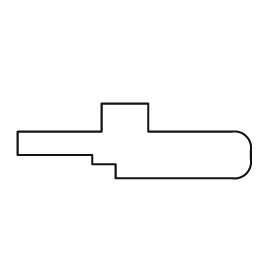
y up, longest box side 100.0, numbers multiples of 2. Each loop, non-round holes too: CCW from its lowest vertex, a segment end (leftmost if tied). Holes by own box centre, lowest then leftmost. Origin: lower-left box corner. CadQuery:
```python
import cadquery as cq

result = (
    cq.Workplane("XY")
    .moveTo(42.0, 0.0)
    .lineTo(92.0, 0.0)
    .threePointArc((98.0, 2.0), (100.0, 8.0))
    .lineTo(100.0, 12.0)
    .threePointArc((98.0, 18.0), (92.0, 20.0))
    .lineTo(56.0, 20.0)
    .lineTo(56.0, 32.0)
    .lineTo(36.0, 32.0)
    .lineTo(36.0, 20.0)
    .lineTo(0.0, 20.0)
    .lineTo(0.0, 10.0)
    .lineTo(32.0, 10.0)
    .lineTo(32.0, 6.0)
    .lineTo(42.0, 6.0)
    .close()
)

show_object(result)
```